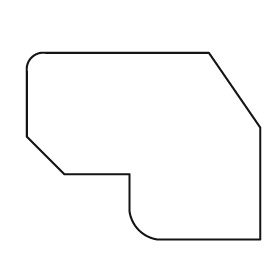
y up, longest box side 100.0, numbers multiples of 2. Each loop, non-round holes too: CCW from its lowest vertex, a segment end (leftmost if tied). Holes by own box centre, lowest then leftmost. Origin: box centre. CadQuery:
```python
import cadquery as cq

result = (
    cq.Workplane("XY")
    .moveTo(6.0, -40.0)
    .lineTo(50.0, -40.0)
    .lineTo(50.0, 8.0)
    .lineTo(28.0, 40.0)
    .lineTo(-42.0, 40.0)
    .threePointArc((-48.0, 38.0), (-50.0, 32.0))
    .lineTo(-50.0, 4.0)
    .lineTo(-34.0, -12.0)
    .lineTo(-6.0, -12.0)
    .lineTo(-6.0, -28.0)
    .threePointArc((-2.0, -36.0), (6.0, -40.0))
    .close()
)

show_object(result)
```